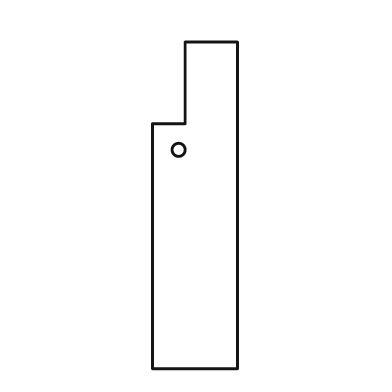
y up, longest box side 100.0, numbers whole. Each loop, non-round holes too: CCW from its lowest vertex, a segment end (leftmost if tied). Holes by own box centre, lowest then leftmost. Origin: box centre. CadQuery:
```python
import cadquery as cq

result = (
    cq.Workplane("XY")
    .moveTo(-13.0, -50.0)
    .lineTo(13.0, -50.0)
    .lineTo(13.0, 50.0)
    .lineTo(-3.0, 50.0)
    .lineTo(-3.0, 25.0)
    .lineTo(-13.0, 25.0)
    .close()
    .moveTo(-5.0, 17.0)
    .circle(2.0)
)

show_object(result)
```